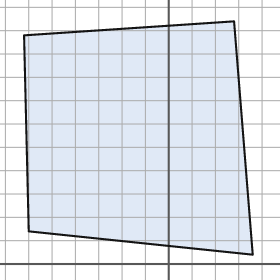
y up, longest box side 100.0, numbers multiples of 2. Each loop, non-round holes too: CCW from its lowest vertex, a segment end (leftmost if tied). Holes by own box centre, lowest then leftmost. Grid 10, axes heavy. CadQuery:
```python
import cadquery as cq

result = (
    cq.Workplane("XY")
    .moveTo(36.0, 4.0)
    .lineTo(28.0, 104.0)
    .lineTo(-62.0, 98.0)
    .lineTo(-60.0, 14.0)
    .close()
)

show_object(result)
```